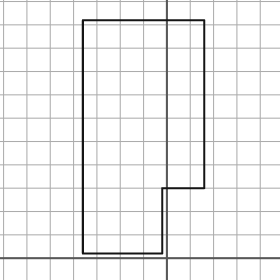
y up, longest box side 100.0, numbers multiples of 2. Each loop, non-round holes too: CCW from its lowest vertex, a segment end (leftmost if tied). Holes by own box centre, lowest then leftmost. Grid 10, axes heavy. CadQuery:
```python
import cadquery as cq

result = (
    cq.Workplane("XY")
    .moveTo(-36.0, 2.0)
    .lineTo(-2.0, 2.0)
    .lineTo(-2.0, 30.0)
    .lineTo(16.0, 30.0)
    .lineTo(16.0, 102.0)
    .lineTo(-36.0, 102.0)
    .close()
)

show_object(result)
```